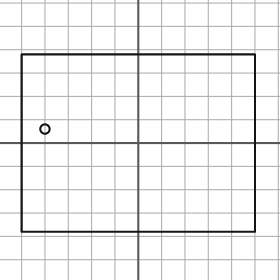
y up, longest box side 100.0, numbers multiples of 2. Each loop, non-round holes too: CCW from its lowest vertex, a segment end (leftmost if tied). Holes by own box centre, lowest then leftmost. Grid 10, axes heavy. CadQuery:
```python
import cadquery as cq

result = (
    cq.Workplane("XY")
    .moveTo(-50.0, -38.0)
    .lineTo(50.0, -38.0)
    .lineTo(50.0, 38.0)
    .lineTo(-50.0, 38.0)
    .close()
    .moveTo(-40.0, 6.0)
    .circle(2.0)
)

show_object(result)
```